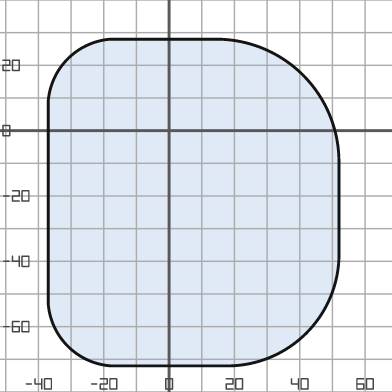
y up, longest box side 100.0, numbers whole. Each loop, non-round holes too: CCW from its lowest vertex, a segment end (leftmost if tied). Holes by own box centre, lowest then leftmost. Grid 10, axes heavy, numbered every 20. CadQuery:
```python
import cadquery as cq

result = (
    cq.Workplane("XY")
    .moveTo(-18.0, -72.0)
    .lineTo(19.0, -72.0)
    .threePointArc((42.0, -62.0), (52.0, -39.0))
    .lineTo(52.0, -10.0)
    .threePointArc((41.0, 17.0), (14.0, 28.0))
    .lineTo(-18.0, 28.0)
    .threePointArc((-31.0, 22.0), (-37.0, 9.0))
    .lineTo(-37.0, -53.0)
    .threePointArc((-31.0, -66.0), (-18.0, -72.0))
    .close()
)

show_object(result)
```